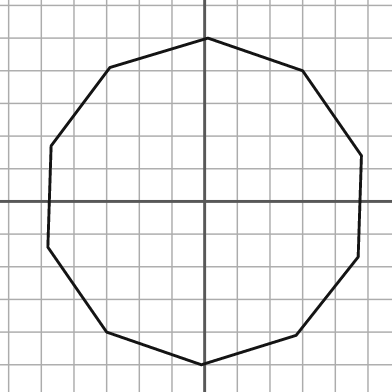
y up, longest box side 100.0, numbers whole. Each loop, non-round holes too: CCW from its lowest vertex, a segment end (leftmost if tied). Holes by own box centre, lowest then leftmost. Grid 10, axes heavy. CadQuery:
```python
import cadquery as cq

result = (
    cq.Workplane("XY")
    .moveTo(-1.0, -50.0)
    .lineTo(28.0, -41.0)
    .lineTo(47.0, -17.0)
    .lineTo(48.0, 14.0)
    .lineTo(30.0, 40.0)
    .lineTo(1.0, 50.0)
    .lineTo(-29.0, 41.0)
    .lineTo(-47.0, 17.0)
    .lineTo(-48.0, -14.0)
    .lineTo(-30.0, -40.0)
    .close()
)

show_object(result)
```